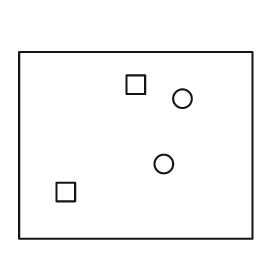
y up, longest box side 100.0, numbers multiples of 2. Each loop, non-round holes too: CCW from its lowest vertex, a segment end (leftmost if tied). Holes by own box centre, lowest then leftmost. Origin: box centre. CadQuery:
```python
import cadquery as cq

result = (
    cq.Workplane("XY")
    .moveTo(-50.0, -40.0)
    .lineTo(50.0, -40.0)
    .lineTo(50.0, 40.0)
    .lineTo(-50.0, 40.0)
    .close()
    .moveTo(-34.0, -24.0)
    .lineTo(-26.0, -24.0)
    .lineTo(-26.0, -16.0)
    .lineTo(-34.0, -16.0)
    .close()
    .moveTo(12.0, -8.0)
    .circle(4.0)
    .moveTo(20.0, 20.0)
    .circle(4.0)
    .moveTo(-4.0, 22.0)
    .lineTo(4.0, 22.0)
    .lineTo(4.0, 30.0)
    .lineTo(-4.0, 30.0)
    .close()
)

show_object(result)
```